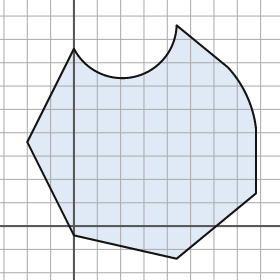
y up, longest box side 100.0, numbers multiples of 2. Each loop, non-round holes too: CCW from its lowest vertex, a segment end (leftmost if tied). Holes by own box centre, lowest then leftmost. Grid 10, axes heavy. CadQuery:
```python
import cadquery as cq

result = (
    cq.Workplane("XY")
    .moveTo(44.0, -14.0)
    .lineTo(78.0, 14.0)
    .lineTo(78.0, 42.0)
    .threePointArc((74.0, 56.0), (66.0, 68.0))
    .lineTo(44.0, 86.0)
    .threePointArc((26.0, 64.0), (0.0, 76.0))
    .lineTo(-20.0, 36.0)
    .lineTo(0.0, -4.0)
    .close()
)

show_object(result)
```